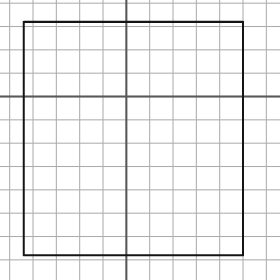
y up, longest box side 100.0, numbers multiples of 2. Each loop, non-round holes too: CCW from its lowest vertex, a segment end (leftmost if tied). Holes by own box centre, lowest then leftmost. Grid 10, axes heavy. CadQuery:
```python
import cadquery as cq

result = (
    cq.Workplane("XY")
    .moveTo(-44.0, -68.0)
    .lineTo(50.0, -68.0)
    .lineTo(50.0, 32.0)
    .lineTo(-44.0, 32.0)
    .close()
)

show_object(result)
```